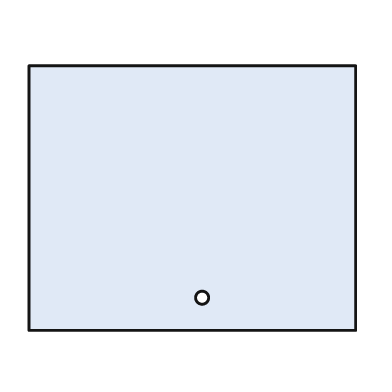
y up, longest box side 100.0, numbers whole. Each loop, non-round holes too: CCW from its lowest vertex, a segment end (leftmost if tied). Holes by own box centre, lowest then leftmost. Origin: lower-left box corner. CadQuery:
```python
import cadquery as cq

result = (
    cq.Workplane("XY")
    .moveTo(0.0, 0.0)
    .lineTo(100.0, 0.0)
    .lineTo(100.0, 81.0)
    .lineTo(0.0, 81.0)
    .close()
    .moveTo(53.0, 10.0)
    .circle(2.0)
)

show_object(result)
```